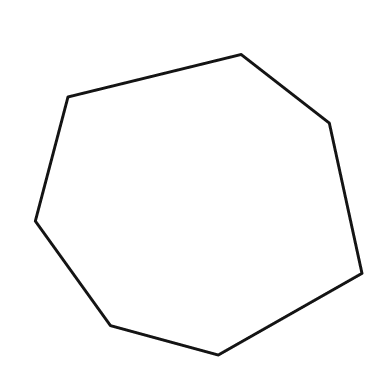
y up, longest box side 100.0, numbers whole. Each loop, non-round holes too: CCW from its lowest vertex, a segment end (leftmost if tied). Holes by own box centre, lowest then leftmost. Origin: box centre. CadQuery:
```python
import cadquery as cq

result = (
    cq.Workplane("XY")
    .moveTo(6.0, -46.0)
    .lineTo(50.0, -21.0)
    .lineTo(40.0, 25.0)
    .lineTo(13.0, 46.0)
    .lineTo(-40.0, 33.0)
    .lineTo(-50.0, -5.0)
    .lineTo(-27.0, -37.0)
    .close()
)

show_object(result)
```